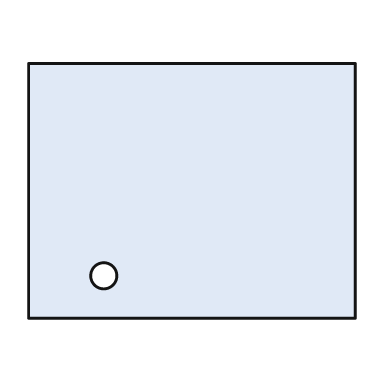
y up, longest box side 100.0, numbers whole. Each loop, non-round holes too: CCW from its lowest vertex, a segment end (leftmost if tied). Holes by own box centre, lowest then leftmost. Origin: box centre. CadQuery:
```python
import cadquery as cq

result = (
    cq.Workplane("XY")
    .moveTo(-50.0, -39.0)
    .lineTo(50.0, -39.0)
    .lineTo(50.0, 39.0)
    .lineTo(-50.0, 39.0)
    .close()
    .moveTo(-27.0, -26.0)
    .circle(4.0)
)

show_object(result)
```